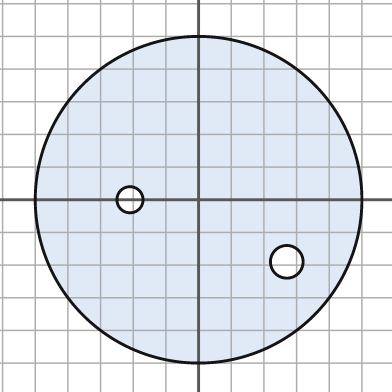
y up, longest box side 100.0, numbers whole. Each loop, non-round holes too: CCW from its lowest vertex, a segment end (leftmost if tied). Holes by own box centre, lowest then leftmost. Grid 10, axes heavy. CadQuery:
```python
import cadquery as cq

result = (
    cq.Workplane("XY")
    .moveTo(0.0, 0.0)
    .circle(50.0)
    .moveTo(27.0, -19.0)
    .circle(5.0)
    .moveTo(-21.0, 0.0)
    .circle(4.0)
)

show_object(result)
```